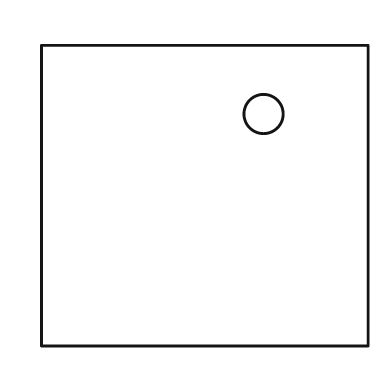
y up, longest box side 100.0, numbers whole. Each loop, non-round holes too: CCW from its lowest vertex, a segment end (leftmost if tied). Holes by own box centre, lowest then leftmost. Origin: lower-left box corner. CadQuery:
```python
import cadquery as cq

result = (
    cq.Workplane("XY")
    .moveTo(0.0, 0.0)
    .lineTo(100.0, 0.0)
    .lineTo(100.0, 92.0)
    .lineTo(0.0, 92.0)
    .close()
    .moveTo(68.0, 71.0)
    .circle(6.0)
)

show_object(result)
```